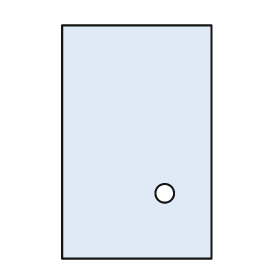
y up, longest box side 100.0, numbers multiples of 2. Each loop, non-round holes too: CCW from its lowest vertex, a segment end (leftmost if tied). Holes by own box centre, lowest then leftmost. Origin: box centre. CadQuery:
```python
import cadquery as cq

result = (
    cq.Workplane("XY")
    .moveTo(-32.0, -50.0)
    .lineTo(32.0, -50.0)
    .lineTo(32.0, 50.0)
    .lineTo(-32.0, 50.0)
    .close()
    .moveTo(12.0, -22.0)
    .circle(4.0)
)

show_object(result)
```